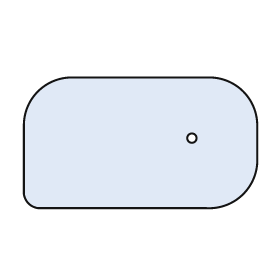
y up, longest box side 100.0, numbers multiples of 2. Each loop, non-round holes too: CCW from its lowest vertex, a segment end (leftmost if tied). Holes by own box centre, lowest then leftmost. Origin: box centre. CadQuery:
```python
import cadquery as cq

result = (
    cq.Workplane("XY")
    .moveTo(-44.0, -28.0)
    .lineTo(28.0, -28.0)
    .threePointArc((44.0, -22.0), (50.0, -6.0))
    .lineTo(50.0, 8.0)
    .threePointArc((44.0, 22.0), (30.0, 28.0))
    .lineTo(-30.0, 28.0)
    .threePointArc((-44.0, 22.0), (-50.0, 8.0))
    .lineTo(-50.0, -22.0)
    .threePointArc((-48.0, -26.0), (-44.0, -28.0))
    .close()
    .moveTo(22.0, 2.0)
    .circle(2.0)
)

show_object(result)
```